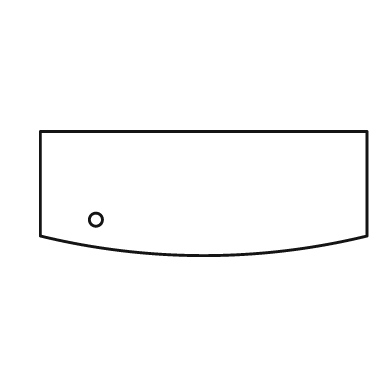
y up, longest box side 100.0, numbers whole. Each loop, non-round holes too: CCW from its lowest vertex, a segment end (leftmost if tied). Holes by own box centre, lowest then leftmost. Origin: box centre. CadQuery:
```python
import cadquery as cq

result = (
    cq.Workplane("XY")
    .moveTo(-50.0, -13.0)
    .threePointArc((0.0, -19.0), (50.0, -13.0))
    .lineTo(50.0, 19.0)
    .lineTo(-50.0, 19.0)
    .close()
    .moveTo(-33.0, -8.0)
    .circle(2.0)
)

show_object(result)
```